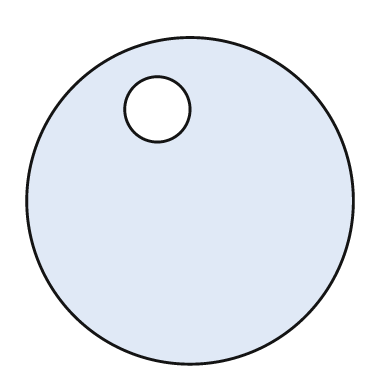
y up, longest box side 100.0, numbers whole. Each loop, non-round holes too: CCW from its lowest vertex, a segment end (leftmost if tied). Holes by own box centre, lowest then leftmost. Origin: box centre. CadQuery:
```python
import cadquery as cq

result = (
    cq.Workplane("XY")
    .moveTo(0.0, 0.0)
    .circle(50.0)
    .moveTo(-10.0, 28.0)
    .circle(10.0)
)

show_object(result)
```